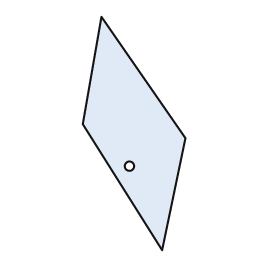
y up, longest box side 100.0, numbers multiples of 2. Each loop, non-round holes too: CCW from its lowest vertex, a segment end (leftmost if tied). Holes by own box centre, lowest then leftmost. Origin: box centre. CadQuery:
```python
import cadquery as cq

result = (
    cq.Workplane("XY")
    .moveTo(12.0, -50.0)
    .lineTo(22.0, -2.0)
    .lineTo(-14.0, 50.0)
    .lineTo(-22.0, 4.0)
    .close()
    .moveTo(-2.0, -14.0)
    .circle(2.0)
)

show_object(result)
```